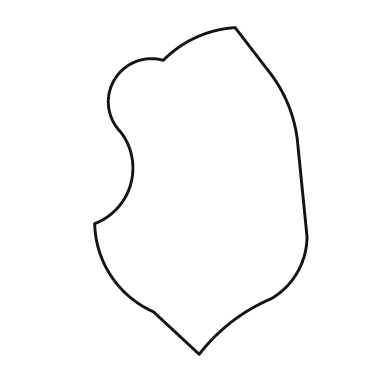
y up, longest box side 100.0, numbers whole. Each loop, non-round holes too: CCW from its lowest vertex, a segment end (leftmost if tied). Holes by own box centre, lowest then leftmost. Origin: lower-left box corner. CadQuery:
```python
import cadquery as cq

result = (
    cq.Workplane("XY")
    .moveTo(32.0, 0.0)
    .threePointArc((42.0, 10.0), (54.0, 17.0))
    .threePointArc((62.0, 25.0), (65.0, 36.0))
    .lineTo(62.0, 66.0)
    .threePointArc((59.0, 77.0), (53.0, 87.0))
    .lineTo(43.0, 100.0)
    .threePointArc((31.0, 97.0), (21.0, 90.0))
    .threePointArc((6.0, 84.0), (8.0, 68.0))
    .threePointArc((11.0, 52.0), (0.0, 40.0))
    .threePointArc((5.0, 24.0), (18.0, 13.0))
    .close()
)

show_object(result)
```